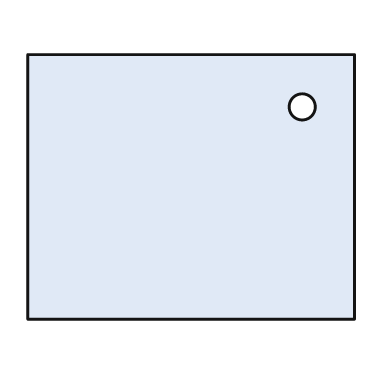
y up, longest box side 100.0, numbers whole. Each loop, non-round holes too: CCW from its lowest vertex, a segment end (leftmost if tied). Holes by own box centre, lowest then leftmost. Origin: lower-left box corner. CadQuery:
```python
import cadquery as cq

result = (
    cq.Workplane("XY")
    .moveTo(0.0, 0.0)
    .lineTo(100.0, 0.0)
    .lineTo(100.0, 81.0)
    .lineTo(0.0, 81.0)
    .close()
    .moveTo(84.0, 65.0)
    .circle(4.0)
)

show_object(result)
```